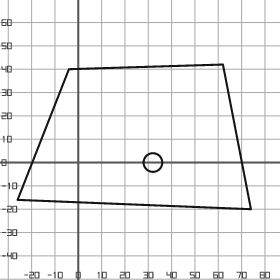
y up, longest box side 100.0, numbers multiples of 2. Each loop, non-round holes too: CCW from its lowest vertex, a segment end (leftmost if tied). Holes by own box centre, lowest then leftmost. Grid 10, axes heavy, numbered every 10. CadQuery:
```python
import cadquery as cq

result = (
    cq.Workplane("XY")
    .moveTo(74.0, -20.0)
    .lineTo(62.0, 42.0)
    .lineTo(-4.0, 40.0)
    .lineTo(-26.0, -16.0)
    .close()
    .moveTo(32.0, 0.0)
    .circle(4.0)
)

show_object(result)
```